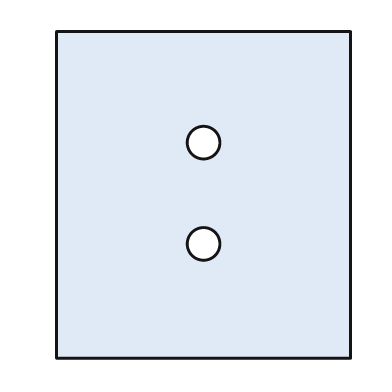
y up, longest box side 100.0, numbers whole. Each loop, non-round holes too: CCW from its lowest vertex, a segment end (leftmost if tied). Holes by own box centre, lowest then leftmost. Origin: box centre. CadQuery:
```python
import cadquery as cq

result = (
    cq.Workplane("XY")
    .moveTo(-45.0, -50.0)
    .lineTo(45.0, -50.0)
    .lineTo(45.0, 50.0)
    .lineTo(-45.0, 50.0)
    .close()
    .moveTo(0.0, -15.0)
    .circle(5.0)
    .moveTo(0.0, 16.0)
    .circle(5.0)
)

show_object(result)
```